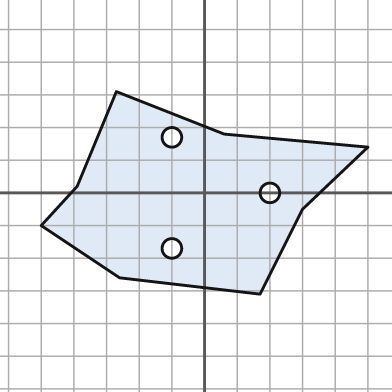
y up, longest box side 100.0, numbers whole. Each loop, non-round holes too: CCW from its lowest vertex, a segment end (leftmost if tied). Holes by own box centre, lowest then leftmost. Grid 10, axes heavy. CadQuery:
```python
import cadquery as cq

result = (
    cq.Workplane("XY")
    .moveTo(17.0, -31.0)
    .lineTo(30.0, -5.0)
    .lineTo(50.0, 14.0)
    .lineTo(6.0, 18.0)
    .lineTo(-27.0, 31.0)
    .lineTo(-39.0, 2.0)
    .lineTo(-50.0, -10.0)
    .lineTo(-26.0, -26.0)
    .close()
    .moveTo(-10.0, -17.0)
    .circle(3.0)
    .moveTo(20.0, 0.0)
    .circle(3.0)
    .moveTo(-10.0, 17.0)
    .circle(3.0)
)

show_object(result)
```